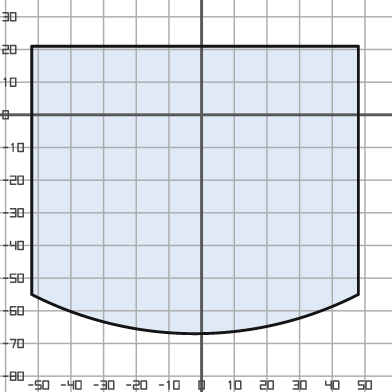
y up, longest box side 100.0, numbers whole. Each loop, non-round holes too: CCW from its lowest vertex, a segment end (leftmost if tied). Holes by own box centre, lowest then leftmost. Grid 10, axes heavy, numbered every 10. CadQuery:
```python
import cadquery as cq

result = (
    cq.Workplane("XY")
    .moveTo(-52.0, -55.0)
    .threePointArc((-2.0, -67.0), (48.0, -55.0))
    .lineTo(48.0, 21.0)
    .lineTo(-52.0, 21.0)
    .close()
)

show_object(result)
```